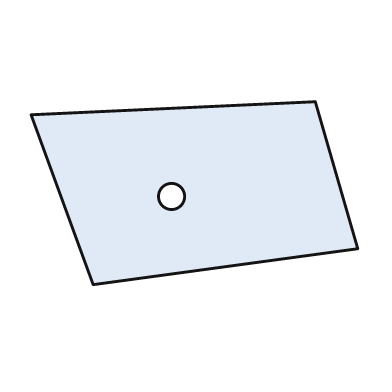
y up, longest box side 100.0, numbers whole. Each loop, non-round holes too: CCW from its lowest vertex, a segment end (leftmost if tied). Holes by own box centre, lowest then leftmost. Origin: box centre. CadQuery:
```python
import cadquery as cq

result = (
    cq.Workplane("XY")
    .moveTo(-31.0, -28.0)
    .lineTo(50.0, -17.0)
    .lineTo(37.0, 28.0)
    .lineTo(-50.0, 24.0)
    .close()
    .moveTo(-7.0, -1.0)
    .circle(4.0)
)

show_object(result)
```